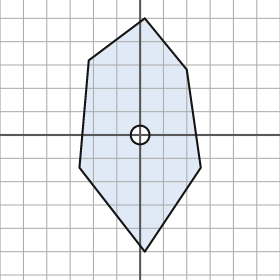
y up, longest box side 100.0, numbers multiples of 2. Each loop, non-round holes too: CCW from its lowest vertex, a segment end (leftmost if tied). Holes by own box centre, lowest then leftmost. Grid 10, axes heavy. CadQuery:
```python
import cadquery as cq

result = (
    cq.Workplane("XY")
    .moveTo(2.0, -50.0)
    .lineTo(26.0, -14.0)
    .lineTo(20.0, 28.0)
    .lineTo(2.0, 50.0)
    .lineTo(-22.0, 32.0)
    .lineTo(-26.0, -14.0)
    .close()
    .moveTo(0.0, 0.0)
    .circle(4.0)
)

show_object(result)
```